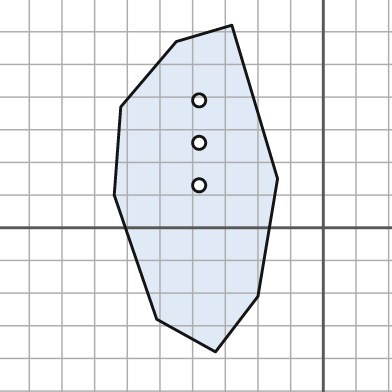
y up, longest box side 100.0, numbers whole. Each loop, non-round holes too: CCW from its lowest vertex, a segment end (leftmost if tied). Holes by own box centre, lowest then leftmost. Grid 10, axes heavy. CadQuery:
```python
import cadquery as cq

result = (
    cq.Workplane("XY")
    .moveTo(-33.0, -38.0)
    .lineTo(-20.0, -21.0)
    .lineTo(-14.0, 15.0)
    .lineTo(-28.0, 62.0)
    .lineTo(-45.0, 57.0)
    .lineTo(-62.0, 37.0)
    .lineTo(-64.0, 10.0)
    .lineTo(-51.0, -28.0)
    .close()
    .moveTo(-38.0, 13.0)
    .circle(2.0)
    .moveTo(-38.0, 26.0)
    .circle(2.0)
    .moveTo(-38.0, 39.0)
    .circle(2.0)
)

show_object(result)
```